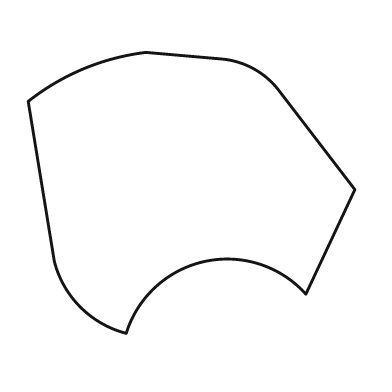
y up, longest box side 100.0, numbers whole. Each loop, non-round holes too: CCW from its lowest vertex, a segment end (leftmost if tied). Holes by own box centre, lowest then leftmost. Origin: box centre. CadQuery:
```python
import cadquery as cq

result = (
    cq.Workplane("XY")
    .moveTo(-20.0, -43.0)
    .threePointArc((4.0, -21.0), (35.0, -31.0))
    .lineTo(50.0, 1.0)
    .lineTo(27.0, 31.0)
    .threePointArc((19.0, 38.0), (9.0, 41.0))
    .lineTo(-14.0, 43.0)
    .threePointArc((-33.0, 38.0), (-50.0, 28.0))
    .lineTo(-42.0, -21.0)
    .threePointArc((-34.0, -35.0), (-20.0, -43.0))
    .close()
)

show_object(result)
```